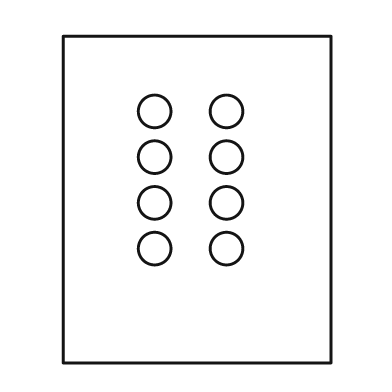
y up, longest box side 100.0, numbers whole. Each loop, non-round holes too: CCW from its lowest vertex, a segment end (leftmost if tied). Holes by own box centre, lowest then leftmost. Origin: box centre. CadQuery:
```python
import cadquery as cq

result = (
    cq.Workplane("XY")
    .moveTo(-41.0, -50.0)
    .lineTo(41.0, -50.0)
    .lineTo(41.0, 50.0)
    .lineTo(-41.0, 50.0)
    .close()
    .moveTo(-13.0, -15.0)
    .circle(5.0)
    .moveTo(9.0, -15.0)
    .circle(5.0)
    .moveTo(-13.0, -1.0)
    .circle(5.0)
    .moveTo(9.0, -1.0)
    .circle(5.0)
    .moveTo(-13.0, 13.0)
    .circle(5.0)
    .moveTo(9.0, 13.0)
    .circle(5.0)
    .moveTo(-13.0, 27.0)
    .circle(5.0)
    .moveTo(9.0, 27.0)
    .circle(5.0)
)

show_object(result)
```